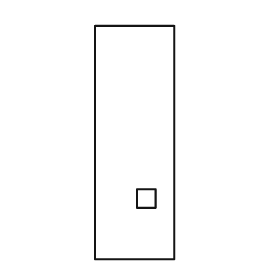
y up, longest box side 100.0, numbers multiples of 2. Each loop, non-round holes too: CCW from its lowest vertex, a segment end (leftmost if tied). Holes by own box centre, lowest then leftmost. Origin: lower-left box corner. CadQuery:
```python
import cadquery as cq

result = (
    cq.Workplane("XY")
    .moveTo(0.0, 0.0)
    .lineTo(34.0, 0.0)
    .lineTo(34.0, 100.0)
    .lineTo(0.0, 100.0)
    .close()
    .moveTo(18.0, 22.0)
    .lineTo(26.0, 22.0)
    .lineTo(26.0, 30.0)
    .lineTo(18.0, 30.0)
    .close()
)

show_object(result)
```